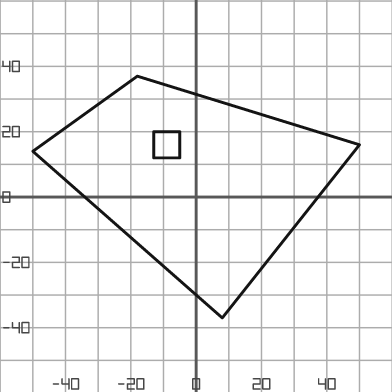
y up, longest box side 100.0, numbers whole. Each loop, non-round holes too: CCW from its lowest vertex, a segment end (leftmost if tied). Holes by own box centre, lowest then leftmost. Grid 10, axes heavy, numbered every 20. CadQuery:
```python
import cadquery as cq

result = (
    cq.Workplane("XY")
    .moveTo(8.0, -37.0)
    .lineTo(50.0, 16.0)
    .lineTo(-18.0, 37.0)
    .lineTo(-50.0, 14.0)
    .close()
    .moveTo(-13.0, 12.0)
    .lineTo(-5.0, 12.0)
    .lineTo(-5.0, 20.0)
    .lineTo(-13.0, 20.0)
    .close()
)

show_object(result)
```